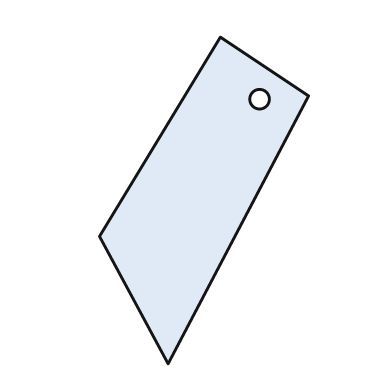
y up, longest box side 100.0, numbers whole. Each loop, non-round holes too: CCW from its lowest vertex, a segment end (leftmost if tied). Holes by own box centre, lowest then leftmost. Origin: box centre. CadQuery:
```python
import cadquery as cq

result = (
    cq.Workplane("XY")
    .moveTo(-11.0, -50.0)
    .lineTo(32.0, 32.0)
    .lineTo(5.0, 50.0)
    .lineTo(-32.0, -11.0)
    .close()
    .moveTo(17.0, 31.0)
    .circle(3.0)
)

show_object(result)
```